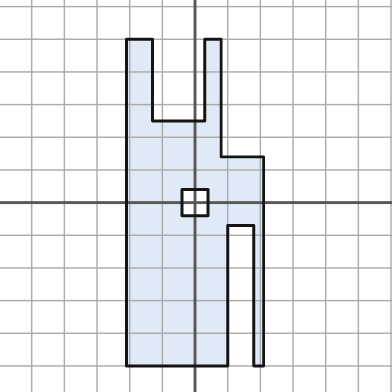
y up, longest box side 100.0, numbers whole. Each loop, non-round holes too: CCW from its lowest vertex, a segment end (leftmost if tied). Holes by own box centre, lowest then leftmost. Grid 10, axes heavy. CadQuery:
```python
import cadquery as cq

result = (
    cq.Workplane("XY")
    .moveTo(-21.0, -50.0)
    .lineTo(10.0, -50.0)
    .lineTo(10.0, -7.0)
    .lineTo(18.0, -7.0)
    .lineTo(18.0, -50.0)
    .lineTo(21.0, -50.0)
    .lineTo(21.0, 14.0)
    .lineTo(8.0, 14.0)
    .lineTo(8.0, 50.0)
    .lineTo(3.0, 50.0)
    .lineTo(3.0, 25.0)
    .lineTo(-13.0, 25.0)
    .lineTo(-13.0, 50.0)
    .lineTo(-21.0, 50.0)
    .close()
    .moveTo(-4.0, -4.0)
    .lineTo(4.0, -4.0)
    .lineTo(4.0, 4.0)
    .lineTo(-4.0, 4.0)
    .close()
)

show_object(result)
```